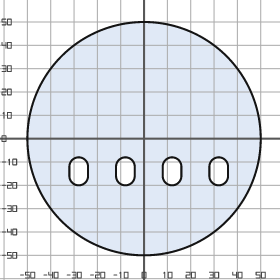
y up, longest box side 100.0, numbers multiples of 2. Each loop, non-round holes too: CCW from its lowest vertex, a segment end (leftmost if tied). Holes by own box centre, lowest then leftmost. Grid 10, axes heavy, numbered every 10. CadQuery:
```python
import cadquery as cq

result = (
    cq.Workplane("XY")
    .moveTo(0.0, 0.0)
    .circle(50.0)
    .moveTo(-32.0, -16.0)
    .threePointArc((-28.0, -20.0), (-24.0, -16.0))
    .lineTo(-24.0, -12.0)
    .threePointArc((-28.0, -8.0), (-32.0, -12.0))
    .close()
    .moveTo(-12.0, -16.0)
    .threePointArc((-8.0, -20.0), (-4.0, -16.0))
    .lineTo(-4.0, -12.0)
    .threePointArc((-8.0, -8.0), (-12.0, -12.0))
    .close()
    .moveTo(8.0, -16.0)
    .threePointArc((12.0, -20.0), (16.0, -16.0))
    .lineTo(16.0, -12.0)
    .threePointArc((12.0, -8.0), (8.0, -12.0))
    .close()
    .moveTo(28.0, -16.0)
    .threePointArc((32.0, -20.0), (36.0, -16.0))
    .lineTo(36.0, -12.0)
    .threePointArc((32.0, -8.0), (28.0, -12.0))
    .close()
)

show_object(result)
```